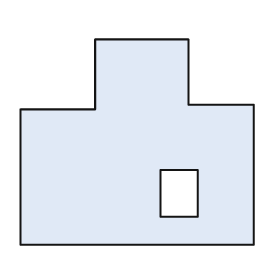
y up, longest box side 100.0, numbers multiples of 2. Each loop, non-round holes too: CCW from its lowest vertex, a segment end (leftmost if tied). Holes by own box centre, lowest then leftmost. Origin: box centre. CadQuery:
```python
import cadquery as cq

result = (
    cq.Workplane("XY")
    .moveTo(-50.0, -44.0)
    .lineTo(50.0, -44.0)
    .lineTo(50.0, 16.0)
    .lineTo(22.0, 16.0)
    .lineTo(22.0, 44.0)
    .lineTo(-18.0, 44.0)
    .lineTo(-18.0, 14.0)
    .lineTo(-50.0, 14.0)
    .close()
    .moveTo(10.0, -32.0)
    .lineTo(26.0, -32.0)
    .lineTo(26.0, -12.0)
    .lineTo(10.0, -12.0)
    .close()
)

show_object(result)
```